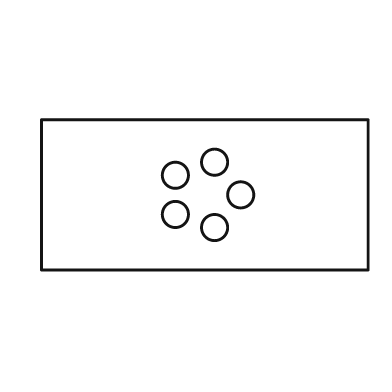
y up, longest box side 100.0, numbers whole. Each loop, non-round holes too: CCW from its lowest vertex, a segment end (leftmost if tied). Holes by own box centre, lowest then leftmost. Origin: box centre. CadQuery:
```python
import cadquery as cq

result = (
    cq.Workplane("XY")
    .moveTo(-50.0, -23.0)
    .lineTo(50.0, -23.0)
    .lineTo(50.0, 23.0)
    .lineTo(-50.0, 23.0)
    .close()
    .moveTo(3.0, -10.0)
    .circle(4.0)
    .moveTo(-9.0, -6.0)
    .circle(4.0)
    .moveTo(11.0, 0.0)
    .circle(4.0)
    .moveTo(-9.0, 6.0)
    .circle(4.0)
    .moveTo(3.0, 10.0)
    .circle(4.0)
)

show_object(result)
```